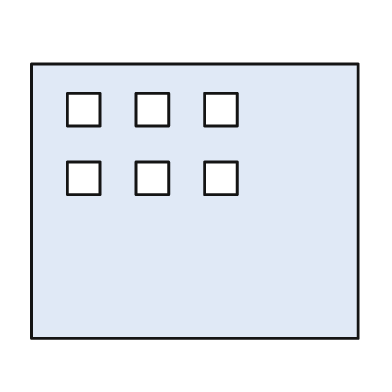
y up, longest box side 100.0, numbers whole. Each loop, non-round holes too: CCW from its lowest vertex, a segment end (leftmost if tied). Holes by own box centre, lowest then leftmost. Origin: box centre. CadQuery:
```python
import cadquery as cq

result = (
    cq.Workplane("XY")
    .moveTo(-50.0, -42.0)
    .lineTo(50.0, -42.0)
    .lineTo(50.0, 42.0)
    .lineTo(-50.0, 42.0)
    .close()
    .moveTo(-39.0, 2.0)
    .lineTo(-29.0, 2.0)
    .lineTo(-29.0, 12.0)
    .lineTo(-39.0, 12.0)
    .close()
    .moveTo(-18.0, 2.0)
    .lineTo(-8.0, 2.0)
    .lineTo(-8.0, 12.0)
    .lineTo(-18.0, 12.0)
    .close()
    .moveTo(3.0, 2.0)
    .lineTo(13.0, 2.0)
    .lineTo(13.0, 12.0)
    .lineTo(3.0, 12.0)
    .close()
    .moveTo(-39.0, 23.0)
    .lineTo(-29.0, 23.0)
    .lineTo(-29.0, 33.0)
    .lineTo(-39.0, 33.0)
    .close()
    .moveTo(-18.0, 23.0)
    .lineTo(-8.0, 23.0)
    .lineTo(-8.0, 33.0)
    .lineTo(-18.0, 33.0)
    .close()
    .moveTo(3.0, 23.0)
    .lineTo(13.0, 23.0)
    .lineTo(13.0, 33.0)
    .lineTo(3.0, 33.0)
    .close()
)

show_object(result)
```